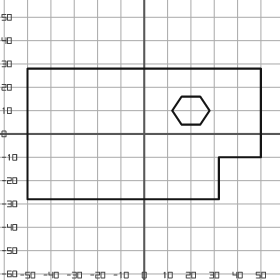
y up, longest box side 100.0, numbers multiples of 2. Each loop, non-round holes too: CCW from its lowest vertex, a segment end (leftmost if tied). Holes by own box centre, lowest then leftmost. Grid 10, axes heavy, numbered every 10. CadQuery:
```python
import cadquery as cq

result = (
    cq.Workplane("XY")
    .moveTo(-50.0, -28.0)
    .lineTo(32.0, -28.0)
    .lineTo(32.0, -10.0)
    .lineTo(50.0, -10.0)
    .lineTo(50.0, 28.0)
    .lineTo(-50.0, 28.0)
    .close()
    .moveTo(16.0, 4.0)
    .lineTo(24.0, 4.0)
    .lineTo(28.0, 10.0)
    .lineTo(24.0, 16.0)
    .lineTo(16.0, 16.0)
    .lineTo(12.0, 10.0)
    .close()
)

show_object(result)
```